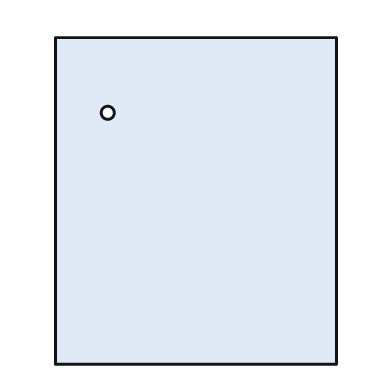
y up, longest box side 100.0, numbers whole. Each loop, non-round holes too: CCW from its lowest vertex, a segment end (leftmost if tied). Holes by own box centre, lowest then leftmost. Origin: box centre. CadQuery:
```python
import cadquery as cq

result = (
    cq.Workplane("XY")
    .moveTo(-43.0, -50.0)
    .lineTo(43.0, -50.0)
    .lineTo(43.0, 50.0)
    .lineTo(-43.0, 50.0)
    .close()
    .moveTo(-27.0, 27.0)
    .circle(2.0)
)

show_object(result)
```